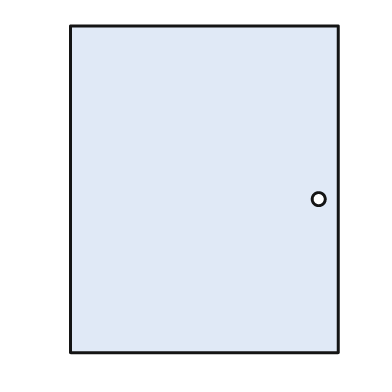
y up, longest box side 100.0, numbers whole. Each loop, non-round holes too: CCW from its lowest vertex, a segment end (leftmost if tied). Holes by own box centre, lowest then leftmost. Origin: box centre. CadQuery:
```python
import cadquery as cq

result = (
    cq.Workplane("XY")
    .moveTo(-41.0, -50.0)
    .lineTo(41.0, -50.0)
    .lineTo(41.0, 50.0)
    .lineTo(-41.0, 50.0)
    .close()
    .moveTo(35.0, -3.0)
    .circle(2.0)
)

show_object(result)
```